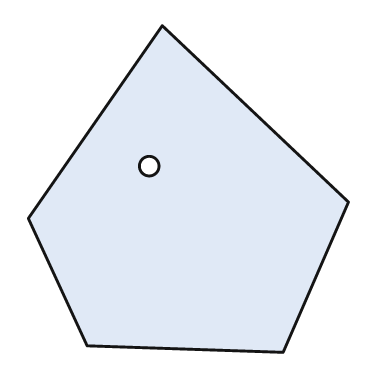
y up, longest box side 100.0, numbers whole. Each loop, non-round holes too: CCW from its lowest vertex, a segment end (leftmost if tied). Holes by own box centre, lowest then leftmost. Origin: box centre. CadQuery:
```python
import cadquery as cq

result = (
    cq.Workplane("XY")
    .moveTo(29.0, -50.0)
    .lineTo(49.0, -4.0)
    .lineTo(-8.0, 50.0)
    .lineTo(-49.0, -9.0)
    .lineTo(-31.0, -48.0)
    .close()
    .moveTo(-12.0, 7.0)
    .circle(3.0)
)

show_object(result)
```